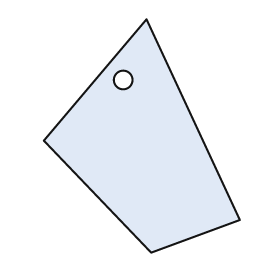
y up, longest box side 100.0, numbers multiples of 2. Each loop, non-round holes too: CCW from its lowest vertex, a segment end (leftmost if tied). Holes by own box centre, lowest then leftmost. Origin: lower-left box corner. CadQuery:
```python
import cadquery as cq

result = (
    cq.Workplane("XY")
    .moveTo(46.0, 0.0)
    .lineTo(84.0, 14.0)
    .lineTo(44.0, 100.0)
    .lineTo(0.0, 48.0)
    .close()
    .moveTo(34.0, 74.0)
    .circle(4.0)
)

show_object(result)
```